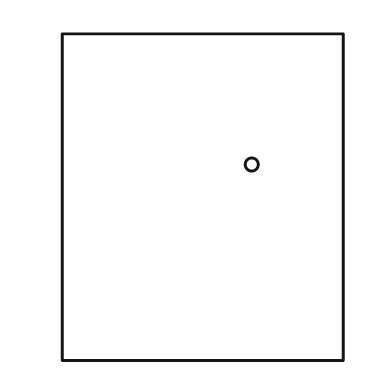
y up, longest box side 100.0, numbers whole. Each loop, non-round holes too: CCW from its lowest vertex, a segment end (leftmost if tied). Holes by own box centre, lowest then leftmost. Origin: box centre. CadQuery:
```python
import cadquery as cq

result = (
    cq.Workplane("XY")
    .moveTo(-43.0, -50.0)
    .lineTo(43.0, -50.0)
    .lineTo(43.0, 50.0)
    .lineTo(-43.0, 50.0)
    .close()
    .moveTo(15.0, 10.0)
    .circle(2.0)
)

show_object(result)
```